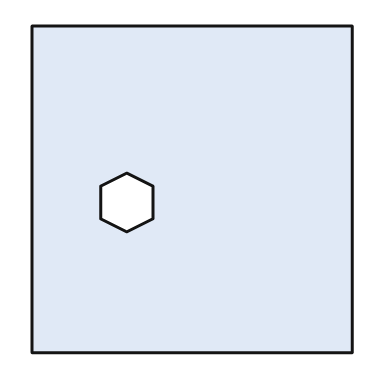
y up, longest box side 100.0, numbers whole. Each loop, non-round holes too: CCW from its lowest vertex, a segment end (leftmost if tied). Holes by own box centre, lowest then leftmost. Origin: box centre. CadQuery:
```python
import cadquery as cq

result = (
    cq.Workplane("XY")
    .moveTo(-49.0, -50.0)
    .lineTo(49.0, -50.0)
    .lineTo(49.0, 50.0)
    .lineTo(-49.0, 50.0)
    .close()
    .moveTo(-20.0, -13.0)
    .lineTo(-12.0, -9.0)
    .lineTo(-12.0, 1.0)
    .lineTo(-20.0, 5.0)
    .lineTo(-28.0, 1.0)
    .lineTo(-28.0, -9.0)
    .close()
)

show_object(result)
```